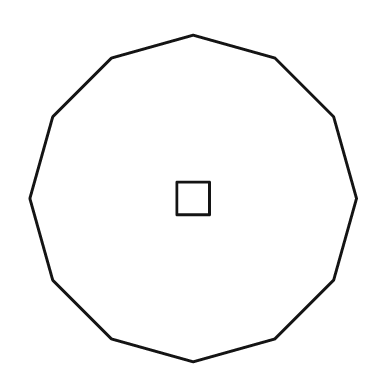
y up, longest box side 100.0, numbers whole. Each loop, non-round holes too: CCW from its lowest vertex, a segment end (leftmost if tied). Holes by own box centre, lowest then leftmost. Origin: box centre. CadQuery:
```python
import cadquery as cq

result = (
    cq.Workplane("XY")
    .moveTo(0.0, -50.0)
    .lineTo(25.0, -43.0)
    .lineTo(43.0, -25.0)
    .lineTo(50.0, 0.0)
    .lineTo(43.0, 25.0)
    .lineTo(25.0, 43.0)
    .lineTo(0.0, 50.0)
    .lineTo(-25.0, 43.0)
    .lineTo(-43.0, 25.0)
    .lineTo(-50.0, 0.0)
    .lineTo(-43.0, -25.0)
    .lineTo(-25.0, -43.0)
    .close()
    .moveTo(-5.0, -5.0)
    .lineTo(5.0, -5.0)
    .lineTo(5.0, 5.0)
    .lineTo(-5.0, 5.0)
    .close()
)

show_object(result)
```